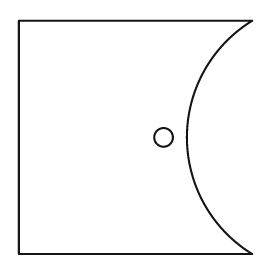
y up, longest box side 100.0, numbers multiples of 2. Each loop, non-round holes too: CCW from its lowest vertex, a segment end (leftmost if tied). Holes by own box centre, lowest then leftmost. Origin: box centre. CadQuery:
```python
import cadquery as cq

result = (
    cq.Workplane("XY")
    .moveTo(-50.0, -50.0)
    .lineTo(50.0, -50.0)
    .threePointArc((22.0, 0.0), (50.0, 50.0))
    .lineTo(-50.0, 50.0)
    .close()
    .moveTo(12.0, 0.0)
    .circle(4.0)
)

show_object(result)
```